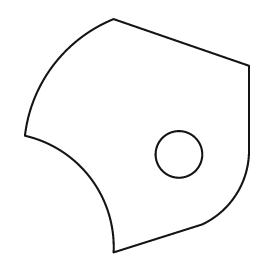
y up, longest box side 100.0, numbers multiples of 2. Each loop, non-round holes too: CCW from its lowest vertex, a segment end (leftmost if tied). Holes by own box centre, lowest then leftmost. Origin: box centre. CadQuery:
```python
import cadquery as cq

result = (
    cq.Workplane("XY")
    .moveTo(-10.0, -50.0)
    .lineTo(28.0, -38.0)
    .threePointArc((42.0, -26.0), (48.0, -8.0))
    .lineTo(48.0, 30.0)
    .lineTo(-10.0, 50.0)
    .threePointArc((-36.0, 30.0), (-48.0, 0.0))
    .threePointArc((-20.0, -18.0), (-10.0, -50.0))
    .close()
    .moveTo(18.0, -8.0)
    .circle(10.0)
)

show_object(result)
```